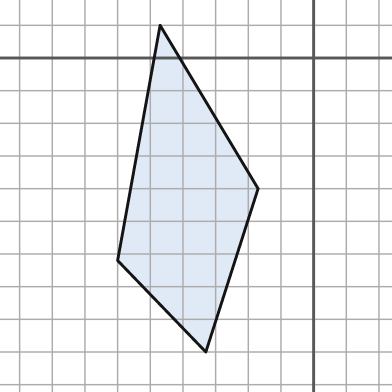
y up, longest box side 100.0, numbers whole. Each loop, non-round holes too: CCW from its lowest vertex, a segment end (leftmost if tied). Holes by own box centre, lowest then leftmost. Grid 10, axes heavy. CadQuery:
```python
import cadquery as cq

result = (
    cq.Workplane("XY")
    .moveTo(-33.0, -90.0)
    .lineTo(-17.0, -40.0)
    .lineTo(-47.0, 10.0)
    .lineTo(-60.0, -62.0)
    .close()
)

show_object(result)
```